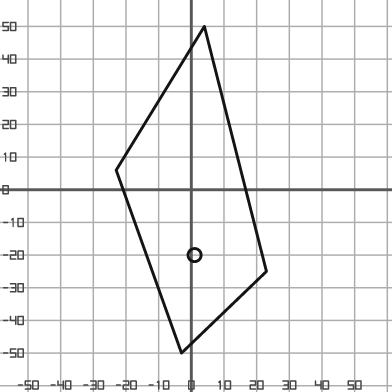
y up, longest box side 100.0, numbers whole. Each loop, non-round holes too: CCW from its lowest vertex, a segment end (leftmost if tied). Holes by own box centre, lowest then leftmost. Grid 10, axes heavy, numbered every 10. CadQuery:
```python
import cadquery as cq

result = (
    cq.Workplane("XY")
    .moveTo(-3.0, -50.0)
    .lineTo(23.0, -25.0)
    .lineTo(4.0, 50.0)
    .lineTo(-23.0, 6.0)
    .close()
    .moveTo(1.0, -20.0)
    .circle(2.0)
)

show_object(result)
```